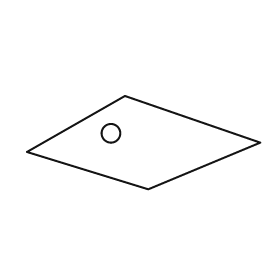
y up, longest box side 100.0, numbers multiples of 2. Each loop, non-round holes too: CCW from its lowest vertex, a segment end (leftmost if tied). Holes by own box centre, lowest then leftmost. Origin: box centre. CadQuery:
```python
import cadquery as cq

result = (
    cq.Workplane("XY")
    .moveTo(2.0, -20.0)
    .lineTo(50.0, 0.0)
    .lineTo(-8.0, 20.0)
    .lineTo(-50.0, -4.0)
    .close()
    .moveTo(-14.0, 4.0)
    .circle(4.0)
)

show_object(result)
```